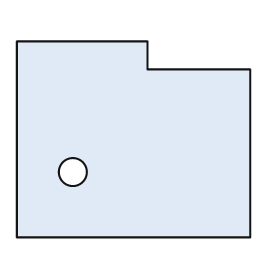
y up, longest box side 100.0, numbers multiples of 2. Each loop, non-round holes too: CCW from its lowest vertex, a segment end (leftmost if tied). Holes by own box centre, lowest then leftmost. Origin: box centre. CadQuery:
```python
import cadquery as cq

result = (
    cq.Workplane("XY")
    .moveTo(-50.0, -42.0)
    .lineTo(50.0, -42.0)
    .lineTo(50.0, 30.0)
    .lineTo(6.0, 30.0)
    .lineTo(6.0, 42.0)
    .lineTo(-50.0, 42.0)
    .close()
    .moveTo(-26.0, -14.0)
    .circle(6.0)
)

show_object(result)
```